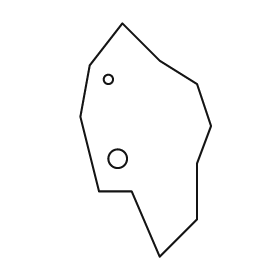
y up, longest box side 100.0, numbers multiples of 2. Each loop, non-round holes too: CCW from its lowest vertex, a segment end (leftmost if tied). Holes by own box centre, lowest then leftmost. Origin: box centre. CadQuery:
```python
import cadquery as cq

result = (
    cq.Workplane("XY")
    .moveTo(6.0, -50.0)
    .lineTo(22.0, -34.0)
    .lineTo(22.0, -10.0)
    .lineTo(28.0, 6.0)
    .lineTo(22.0, 24.0)
    .lineTo(6.0, 34.0)
    .lineTo(-10.0, 50.0)
    .lineTo(-24.0, 32.0)
    .lineTo(-28.0, 10.0)
    .lineTo(-20.0, -22.0)
    .lineTo(-6.0, -22.0)
    .close()
    .moveTo(-12.0, -8.0)
    .circle(4.0)
    .moveTo(-16.0, 26.0)
    .circle(2.0)
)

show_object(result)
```